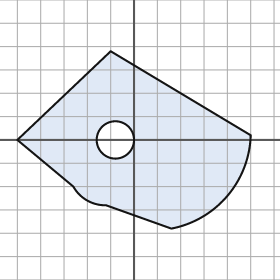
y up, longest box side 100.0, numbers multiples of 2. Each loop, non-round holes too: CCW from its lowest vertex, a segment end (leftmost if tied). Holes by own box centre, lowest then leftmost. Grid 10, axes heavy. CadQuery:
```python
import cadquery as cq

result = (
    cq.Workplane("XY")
    .moveTo(16.0, -38.0)
    .threePointArc((40.0, -24.0), (50.0, 2.0))
    .lineTo(-10.0, 38.0)
    .lineTo(-50.0, 0.0)
    .lineTo(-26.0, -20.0)
    .threePointArc((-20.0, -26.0), (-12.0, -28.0))
    .close()
    .moveTo(-8.0, 0.0)
    .circle(8.0)
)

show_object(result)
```